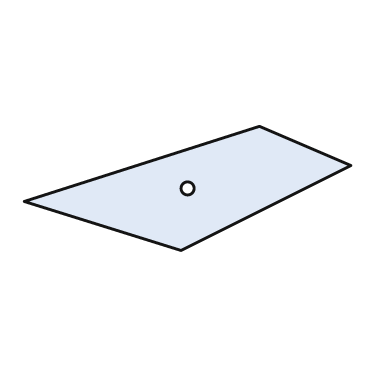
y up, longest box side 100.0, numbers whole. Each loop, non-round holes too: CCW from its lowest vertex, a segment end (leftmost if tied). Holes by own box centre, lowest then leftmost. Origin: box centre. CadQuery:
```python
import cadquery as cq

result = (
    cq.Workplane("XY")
    .moveTo(-2.0, -19.0)
    .lineTo(50.0, 7.0)
    .lineTo(22.0, 19.0)
    .lineTo(-50.0, -4.0)
    .close()
    .moveTo(0.0, 0.0)
    .circle(2.0)
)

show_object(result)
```